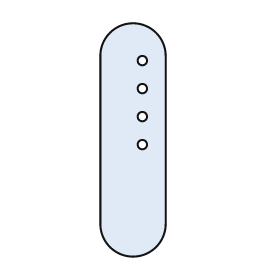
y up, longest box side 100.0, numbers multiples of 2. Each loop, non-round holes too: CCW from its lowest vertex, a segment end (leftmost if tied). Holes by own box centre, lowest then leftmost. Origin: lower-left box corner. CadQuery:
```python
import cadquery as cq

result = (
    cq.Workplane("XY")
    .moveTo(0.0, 14.0)
    .threePointArc((14.0, 0.0), (28.0, 14.0))
    .lineTo(28.0, 86.0)
    .threePointArc((14.0, 100.0), (0.0, 86.0))
    .close()
    .moveTo(18.0, 48.0)
    .circle(2.0)
    .moveTo(18.0, 60.0)
    .circle(2.0)
    .moveTo(18.0, 72.0)
    .circle(2.0)
    .moveTo(18.0, 84.0)
    .circle(2.0)
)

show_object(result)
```